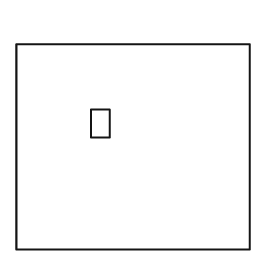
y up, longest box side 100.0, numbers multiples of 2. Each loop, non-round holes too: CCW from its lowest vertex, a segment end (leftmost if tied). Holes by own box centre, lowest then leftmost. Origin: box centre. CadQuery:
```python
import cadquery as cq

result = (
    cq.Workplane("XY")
    .moveTo(-50.0, -44.0)
    .lineTo(50.0, -44.0)
    .lineTo(50.0, 44.0)
    .lineTo(-50.0, 44.0)
    .close()
    .moveTo(-18.0, 4.0)
    .lineTo(-10.0, 4.0)
    .lineTo(-10.0, 16.0)
    .lineTo(-18.0, 16.0)
    .close()
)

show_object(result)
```